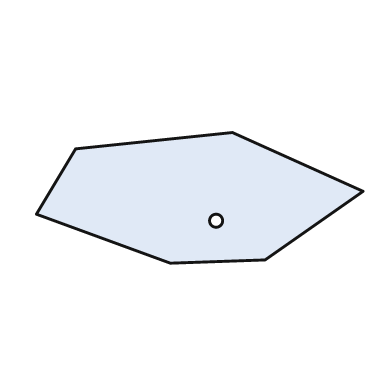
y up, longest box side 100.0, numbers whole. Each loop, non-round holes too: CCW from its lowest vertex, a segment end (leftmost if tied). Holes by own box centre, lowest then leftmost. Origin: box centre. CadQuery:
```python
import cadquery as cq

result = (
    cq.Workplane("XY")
    .moveTo(-9.0, -20.0)
    .lineTo(20.0, -19.0)
    .lineTo(50.0, 2.0)
    .lineTo(10.0, 20.0)
    .lineTo(-38.0, 15.0)
    .lineTo(-50.0, -5.0)
    .close()
    .moveTo(5.0, -7.0)
    .circle(2.0)
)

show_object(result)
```